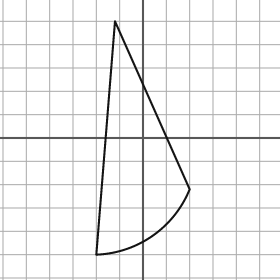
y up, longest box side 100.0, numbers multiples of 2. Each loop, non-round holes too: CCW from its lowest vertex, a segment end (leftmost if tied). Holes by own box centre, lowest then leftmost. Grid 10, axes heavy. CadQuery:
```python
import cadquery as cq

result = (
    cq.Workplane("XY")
    .moveTo(-20.0, -50.0)
    .threePointArc((4.0, -42.0), (20.0, -22.0))
    .lineTo(-12.0, 50.0)
    .close()
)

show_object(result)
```